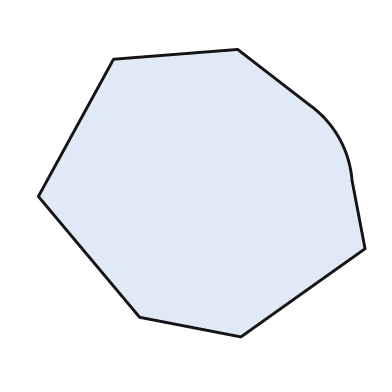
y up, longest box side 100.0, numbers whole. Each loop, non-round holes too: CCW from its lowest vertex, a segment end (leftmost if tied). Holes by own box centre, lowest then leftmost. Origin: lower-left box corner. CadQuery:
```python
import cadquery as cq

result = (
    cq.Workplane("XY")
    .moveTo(62.0, 0.0)
    .lineTo(100.0, 27.0)
    .lineTo(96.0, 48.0)
    .threePointArc((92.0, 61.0), (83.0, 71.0))
    .lineTo(61.0, 88.0)
    .lineTo(23.0, 85.0)
    .lineTo(0.0, 43.0)
    .lineTo(31.0, 6.0)
    .close()
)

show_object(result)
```